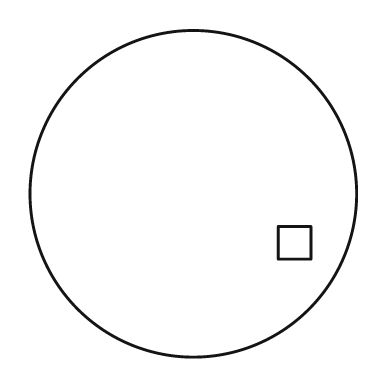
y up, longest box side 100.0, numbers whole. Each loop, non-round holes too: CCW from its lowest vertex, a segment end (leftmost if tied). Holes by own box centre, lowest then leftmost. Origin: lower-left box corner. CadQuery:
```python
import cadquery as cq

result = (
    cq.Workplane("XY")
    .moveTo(50.0, 50.0)
    .circle(50.0)
    .moveTo(76.0, 30.0)
    .lineTo(86.0, 30.0)
    .lineTo(86.0, 40.0)
    .lineTo(76.0, 40.0)
    .close()
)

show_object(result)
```